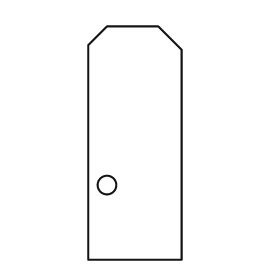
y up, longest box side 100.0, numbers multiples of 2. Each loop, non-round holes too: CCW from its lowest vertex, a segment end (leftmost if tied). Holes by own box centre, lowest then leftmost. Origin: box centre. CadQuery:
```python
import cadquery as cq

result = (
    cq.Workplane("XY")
    .moveTo(-20.0, -50.0)
    .lineTo(20.0, -50.0)
    .lineTo(20.0, 40.0)
    .lineTo(10.0, 50.0)
    .lineTo(-12.0, 50.0)
    .lineTo(-20.0, 42.0)
    .close()
    .moveTo(-12.0, -18.0)
    .circle(4.0)
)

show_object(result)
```